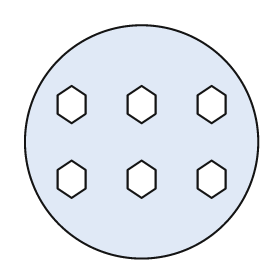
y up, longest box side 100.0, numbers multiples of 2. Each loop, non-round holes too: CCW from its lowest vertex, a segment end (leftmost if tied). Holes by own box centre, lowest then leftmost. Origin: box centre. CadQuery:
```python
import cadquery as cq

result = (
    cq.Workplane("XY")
    .moveTo(0.0, 0.0)
    .circle(50.0)
    .moveTo(-30.0, -24.0)
    .lineTo(-24.0, -20.0)
    .lineTo(-24.0, -12.0)
    .lineTo(-30.0, -8.0)
    .lineTo(-36.0, -12.0)
    .lineTo(-36.0, -20.0)
    .close()
    .moveTo(0.0, -24.0)
    .lineTo(6.0, -20.0)
    .lineTo(6.0, -12.0)
    .lineTo(0.0, -8.0)
    .lineTo(-6.0, -12.0)
    .lineTo(-6.0, -20.0)
    .close()
    .moveTo(30.0, -24.0)
    .lineTo(36.0, -20.0)
    .lineTo(36.0, -12.0)
    .lineTo(30.0, -8.0)
    .lineTo(24.0, -12.0)
    .lineTo(24.0, -20.0)
    .close()
    .moveTo(-30.0, 8.0)
    .lineTo(-24.0, 12.0)
    .lineTo(-24.0, 20.0)
    .lineTo(-30.0, 24.0)
    .lineTo(-36.0, 20.0)
    .lineTo(-36.0, 12.0)
    .close()
    .moveTo(0.0, 8.0)
    .lineTo(6.0, 12.0)
    .lineTo(6.0, 20.0)
    .lineTo(0.0, 24.0)
    .lineTo(-6.0, 20.0)
    .lineTo(-6.0, 12.0)
    .close()
    .moveTo(30.0, 8.0)
    .lineTo(36.0, 12.0)
    .lineTo(36.0, 20.0)
    .lineTo(30.0, 24.0)
    .lineTo(24.0, 20.0)
    .lineTo(24.0, 12.0)
    .close()
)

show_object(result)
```